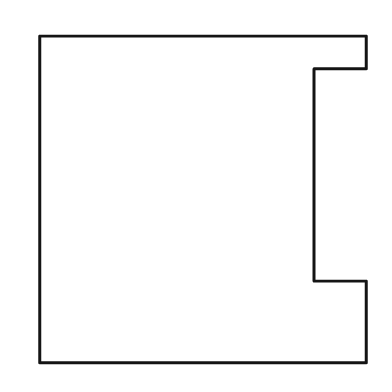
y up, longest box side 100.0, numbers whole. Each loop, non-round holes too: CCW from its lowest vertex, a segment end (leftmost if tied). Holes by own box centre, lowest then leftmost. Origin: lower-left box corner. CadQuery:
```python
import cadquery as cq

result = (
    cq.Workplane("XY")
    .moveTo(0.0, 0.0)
    .lineTo(100.0, 0.0)
    .lineTo(100.0, 25.0)
    .lineTo(84.0, 25.0)
    .lineTo(84.0, 90.0)
    .lineTo(100.0, 90.0)
    .lineTo(100.0, 100.0)
    .lineTo(0.0, 100.0)
    .close()
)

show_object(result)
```